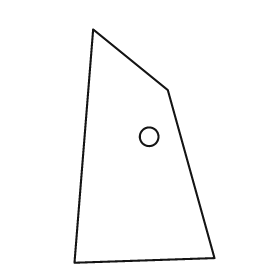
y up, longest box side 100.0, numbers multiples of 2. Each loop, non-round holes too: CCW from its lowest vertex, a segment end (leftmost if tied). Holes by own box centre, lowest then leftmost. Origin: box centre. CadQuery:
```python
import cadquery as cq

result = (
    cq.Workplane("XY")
    .moveTo(-30.0, -50.0)
    .lineTo(30.0, -48.0)
    .lineTo(10.0, 24.0)
    .lineTo(-22.0, 50.0)
    .close()
    .moveTo(2.0, 4.0)
    .circle(4.0)
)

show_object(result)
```